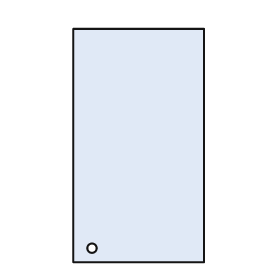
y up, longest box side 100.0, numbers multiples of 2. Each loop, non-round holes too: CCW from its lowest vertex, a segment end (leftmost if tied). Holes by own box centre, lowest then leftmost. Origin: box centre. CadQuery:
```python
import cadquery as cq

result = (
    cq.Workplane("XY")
    .moveTo(-28.0, -50.0)
    .lineTo(28.0, -50.0)
    .lineTo(28.0, 50.0)
    .lineTo(-28.0, 50.0)
    .close()
    .moveTo(-20.0, -44.0)
    .circle(2.0)
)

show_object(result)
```